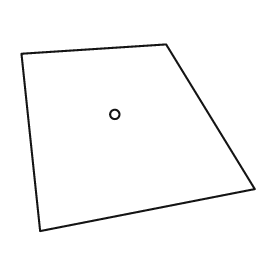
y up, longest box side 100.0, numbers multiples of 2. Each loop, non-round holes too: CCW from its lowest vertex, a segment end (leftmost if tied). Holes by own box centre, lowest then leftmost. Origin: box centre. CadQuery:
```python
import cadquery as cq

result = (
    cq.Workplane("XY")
    .moveTo(-42.0, -40.0)
    .lineTo(50.0, -22.0)
    .lineTo(12.0, 40.0)
    .lineTo(-50.0, 36.0)
    .close()
    .moveTo(-10.0, 10.0)
    .circle(2.0)
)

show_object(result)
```